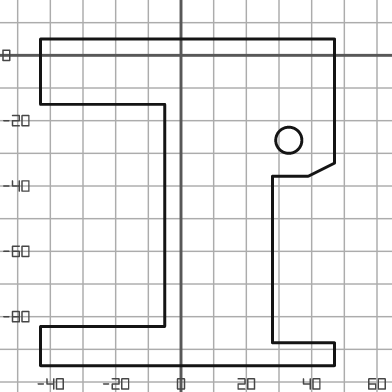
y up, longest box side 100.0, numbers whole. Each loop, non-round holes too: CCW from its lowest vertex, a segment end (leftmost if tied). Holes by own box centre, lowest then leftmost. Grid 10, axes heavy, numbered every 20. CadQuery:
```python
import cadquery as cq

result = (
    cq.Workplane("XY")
    .moveTo(-43.0, -95.0)
    .lineTo(47.0, -95.0)
    .lineTo(47.0, -88.0)
    .lineTo(28.0, -88.0)
    .lineTo(28.0, -37.0)
    .lineTo(39.0, -37.0)
    .lineTo(47.0, -33.0)
    .lineTo(47.0, 5.0)
    .lineTo(-43.0, 5.0)
    .lineTo(-43.0, -15.0)
    .lineTo(-5.0, -15.0)
    .lineTo(-5.0, -83.0)
    .lineTo(-43.0, -83.0)
    .close()
    .moveTo(33.0, -26.0)
    .circle(4.0)
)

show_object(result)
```